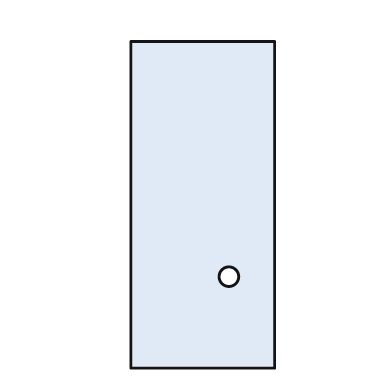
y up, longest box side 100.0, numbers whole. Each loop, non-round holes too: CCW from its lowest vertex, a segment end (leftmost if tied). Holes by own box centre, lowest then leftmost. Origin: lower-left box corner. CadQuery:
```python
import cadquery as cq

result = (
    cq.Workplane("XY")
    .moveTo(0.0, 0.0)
    .lineTo(44.0, 0.0)
    .lineTo(44.0, 100.0)
    .lineTo(0.0, 100.0)
    .close()
    .moveTo(30.0, 28.0)
    .circle(3.0)
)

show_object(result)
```